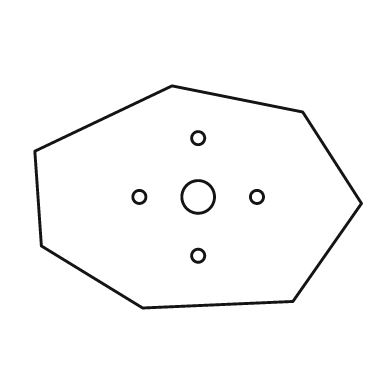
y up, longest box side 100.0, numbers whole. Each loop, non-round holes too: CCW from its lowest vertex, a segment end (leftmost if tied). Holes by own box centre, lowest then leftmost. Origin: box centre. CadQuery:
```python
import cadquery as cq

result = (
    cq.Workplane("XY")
    .moveTo(-17.0, -34.0)
    .lineTo(29.0, -32.0)
    .lineTo(50.0, -2.0)
    .lineTo(32.0, 26.0)
    .lineTo(-8.0, 34.0)
    .lineTo(-50.0, 14.0)
    .lineTo(-48.0, -15.0)
    .close()
    .moveTo(0.0, -18.0)
    .circle(2.0)
    .moveTo(-18.0, 0.0)
    .circle(2.0)
    .moveTo(0.0, 0.0)
    .circle(5.0)
    .moveTo(18.0, 0.0)
    .circle(2.0)
    .moveTo(0.0, 18.0)
    .circle(2.0)
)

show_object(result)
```